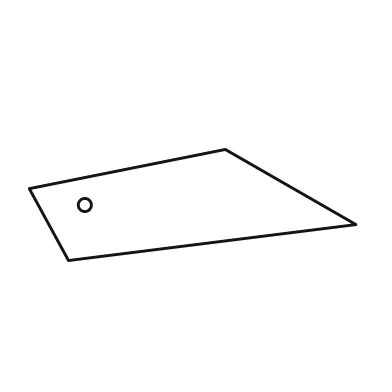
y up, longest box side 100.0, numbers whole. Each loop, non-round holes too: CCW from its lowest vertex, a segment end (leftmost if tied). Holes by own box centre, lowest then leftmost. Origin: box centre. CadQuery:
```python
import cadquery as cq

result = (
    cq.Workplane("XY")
    .moveTo(-38.0, -17.0)
    .lineTo(50.0, -6.0)
    .lineTo(10.0, 17.0)
    .lineTo(-50.0, 5.0)
    .close()
    .moveTo(-33.0, 0.0)
    .circle(2.0)
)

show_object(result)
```